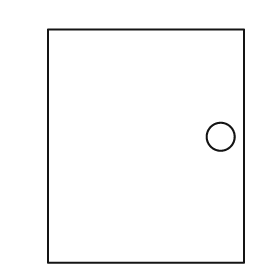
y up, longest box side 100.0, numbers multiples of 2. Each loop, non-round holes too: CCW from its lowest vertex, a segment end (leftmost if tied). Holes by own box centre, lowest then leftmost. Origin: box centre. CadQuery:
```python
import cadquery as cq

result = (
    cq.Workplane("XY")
    .moveTo(-42.0, -50.0)
    .lineTo(42.0, -50.0)
    .lineTo(42.0, 50.0)
    .lineTo(-42.0, 50.0)
    .close()
    .moveTo(32.0, 4.0)
    .circle(6.0)
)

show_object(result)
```